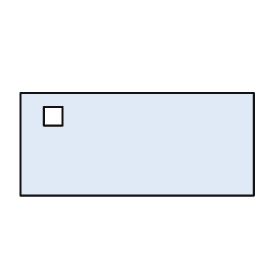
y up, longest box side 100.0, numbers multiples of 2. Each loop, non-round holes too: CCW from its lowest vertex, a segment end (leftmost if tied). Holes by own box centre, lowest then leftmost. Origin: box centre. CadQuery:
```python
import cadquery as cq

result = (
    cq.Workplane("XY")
    .moveTo(-50.0, -22.0)
    .lineTo(50.0, -22.0)
    .lineTo(50.0, 22.0)
    .lineTo(-50.0, 22.0)
    .close()
    .moveTo(-40.0, 8.0)
    .lineTo(-32.0, 8.0)
    .lineTo(-32.0, 16.0)
    .lineTo(-40.0, 16.0)
    .close()
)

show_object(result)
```